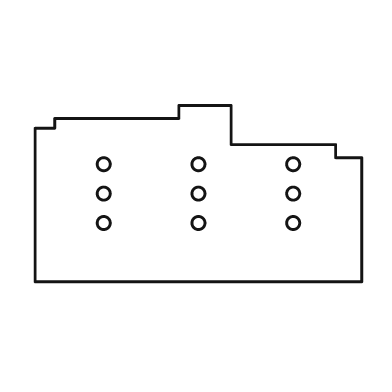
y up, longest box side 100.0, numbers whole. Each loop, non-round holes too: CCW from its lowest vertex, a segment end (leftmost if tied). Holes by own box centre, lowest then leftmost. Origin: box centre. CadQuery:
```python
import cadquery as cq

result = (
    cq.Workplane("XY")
    .moveTo(-50.0, -27.0)
    .lineTo(50.0, -27.0)
    .lineTo(50.0, 11.0)
    .lineTo(42.0, 11.0)
    .lineTo(42.0, 15.0)
    .lineTo(10.0, 15.0)
    .lineTo(10.0, 27.0)
    .lineTo(-6.0, 27.0)
    .lineTo(-6.0, 23.0)
    .lineTo(-44.0, 23.0)
    .lineTo(-44.0, 20.0)
    .lineTo(-50.0, 20.0)
    .close()
    .moveTo(-29.0, -9.0)
    .circle(2.0)
    .moveTo(0.0, -9.0)
    .circle(2.0)
    .moveTo(29.0, -9.0)
    .circle(2.0)
    .moveTo(-29.0, 0.0)
    .circle(2.0)
    .moveTo(0.0, 0.0)
    .circle(2.0)
    .moveTo(29.0, 0.0)
    .circle(2.0)
    .moveTo(-29.0, 9.0)
    .circle(2.0)
    .moveTo(0.0, 9.0)
    .circle(2.0)
    .moveTo(29.0, 9.0)
    .circle(2.0)
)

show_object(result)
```